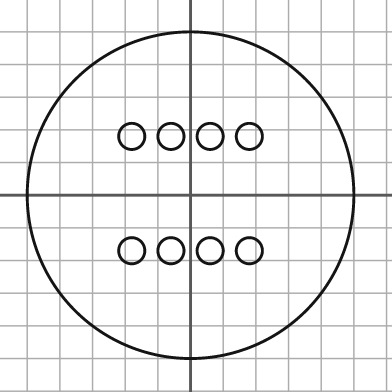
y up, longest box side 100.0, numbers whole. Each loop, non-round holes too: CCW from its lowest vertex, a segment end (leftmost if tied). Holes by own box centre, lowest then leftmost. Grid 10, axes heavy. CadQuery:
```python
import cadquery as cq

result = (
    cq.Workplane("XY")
    .moveTo(0.0, 0.0)
    .circle(50.0)
    .moveTo(-18.0, -17.0)
    .circle(4.0)
    .moveTo(-6.0, -17.0)
    .circle(4.0)
    .moveTo(6.0, -17.0)
    .circle(4.0)
    .moveTo(18.0, -17.0)
    .circle(4.0)
    .moveTo(-18.0, 18.0)
    .circle(4.0)
    .moveTo(-6.0, 18.0)
    .circle(4.0)
    .moveTo(6.0, 18.0)
    .circle(4.0)
    .moveTo(18.0, 18.0)
    .circle(4.0)
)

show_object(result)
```